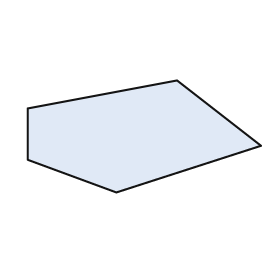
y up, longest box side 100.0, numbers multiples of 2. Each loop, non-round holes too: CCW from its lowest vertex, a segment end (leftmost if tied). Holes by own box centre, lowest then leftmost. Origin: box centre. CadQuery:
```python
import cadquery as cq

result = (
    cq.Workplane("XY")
    .moveTo(-12.0, -24.0)
    .lineTo(50.0, -4.0)
    .lineTo(14.0, 24.0)
    .lineTo(-50.0, 12.0)
    .lineTo(-50.0, -10.0)
    .close()
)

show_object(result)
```